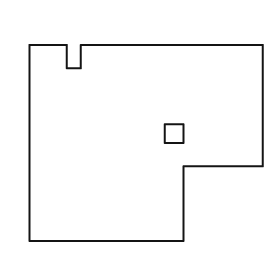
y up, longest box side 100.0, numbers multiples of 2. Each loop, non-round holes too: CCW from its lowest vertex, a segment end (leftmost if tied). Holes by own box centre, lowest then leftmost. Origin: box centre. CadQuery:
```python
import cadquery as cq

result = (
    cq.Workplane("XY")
    .moveTo(-50.0, -42.0)
    .lineTo(16.0, -42.0)
    .lineTo(16.0, -10.0)
    .lineTo(50.0, -10.0)
    .lineTo(50.0, 42.0)
    .lineTo(-28.0, 42.0)
    .lineTo(-28.0, 32.0)
    .lineTo(-34.0, 32.0)
    .lineTo(-34.0, 42.0)
    .lineTo(-50.0, 42.0)
    .close()
    .moveTo(8.0, 0.0)
    .lineTo(16.0, 0.0)
    .lineTo(16.0, 8.0)
    .lineTo(8.0, 8.0)
    .close()
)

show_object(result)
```